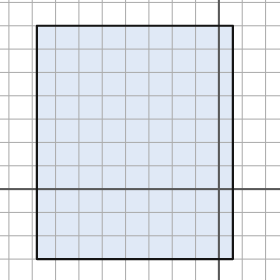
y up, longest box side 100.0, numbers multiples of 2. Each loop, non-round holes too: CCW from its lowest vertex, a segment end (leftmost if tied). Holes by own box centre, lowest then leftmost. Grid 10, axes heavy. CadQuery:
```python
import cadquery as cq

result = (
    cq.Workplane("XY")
    .moveTo(-78.0, -30.0)
    .lineTo(6.0, -30.0)
    .lineTo(6.0, 70.0)
    .lineTo(-78.0, 70.0)
    .close()
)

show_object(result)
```